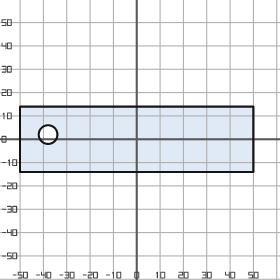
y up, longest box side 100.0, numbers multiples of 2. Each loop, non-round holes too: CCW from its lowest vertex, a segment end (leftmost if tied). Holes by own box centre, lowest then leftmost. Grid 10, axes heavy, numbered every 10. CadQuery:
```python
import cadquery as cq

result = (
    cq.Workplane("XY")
    .moveTo(-50.0, -14.0)
    .lineTo(50.0, -14.0)
    .lineTo(50.0, 14.0)
    .lineTo(-50.0, 14.0)
    .close()
    .moveTo(-38.0, 2.0)
    .circle(4.0)
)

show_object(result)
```